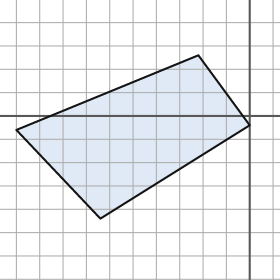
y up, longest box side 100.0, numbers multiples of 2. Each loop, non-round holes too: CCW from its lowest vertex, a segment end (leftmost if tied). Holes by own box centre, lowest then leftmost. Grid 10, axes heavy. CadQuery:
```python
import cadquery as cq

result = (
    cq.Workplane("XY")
    .moveTo(-64.0, -44.0)
    .lineTo(0.0, -4.0)
    .lineTo(-22.0, 26.0)
    .lineTo(-100.0, -6.0)
    .close()
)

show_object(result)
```